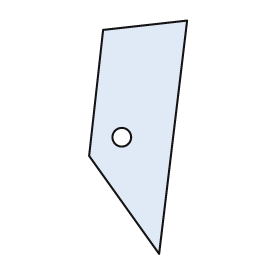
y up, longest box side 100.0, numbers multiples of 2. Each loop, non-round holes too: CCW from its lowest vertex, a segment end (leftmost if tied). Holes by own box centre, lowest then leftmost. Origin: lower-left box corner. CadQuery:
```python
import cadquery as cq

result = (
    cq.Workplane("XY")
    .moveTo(30.0, 0.0)
    .lineTo(42.0, 100.0)
    .lineTo(6.0, 96.0)
    .lineTo(0.0, 42.0)
    .close()
    .moveTo(14.0, 50.0)
    .circle(4.0)
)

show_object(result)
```